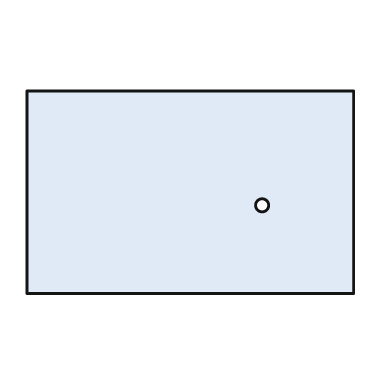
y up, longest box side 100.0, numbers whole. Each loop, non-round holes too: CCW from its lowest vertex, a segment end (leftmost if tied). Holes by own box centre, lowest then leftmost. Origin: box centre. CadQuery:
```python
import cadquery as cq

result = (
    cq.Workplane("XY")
    .moveTo(-50.0, -31.0)
    .lineTo(50.0, -31.0)
    .lineTo(50.0, 31.0)
    .lineTo(-50.0, 31.0)
    .close()
    .moveTo(22.0, -4.0)
    .circle(2.0)
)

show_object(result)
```